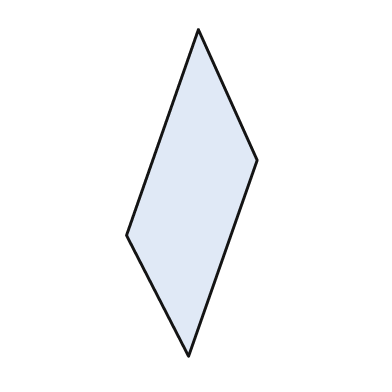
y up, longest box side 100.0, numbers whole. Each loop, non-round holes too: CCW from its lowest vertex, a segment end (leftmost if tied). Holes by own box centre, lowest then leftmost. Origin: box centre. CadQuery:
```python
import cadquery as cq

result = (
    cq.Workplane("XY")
    .moveTo(-1.0, -50.0)
    .lineTo(20.0, 10.0)
    .lineTo(2.0, 50.0)
    .lineTo(-20.0, -13.0)
    .close()
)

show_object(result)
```